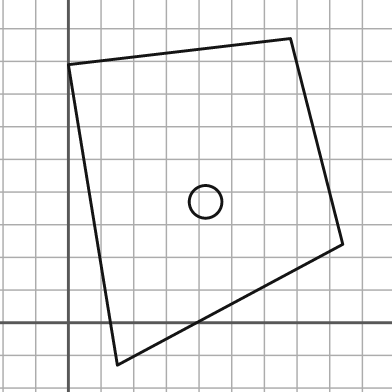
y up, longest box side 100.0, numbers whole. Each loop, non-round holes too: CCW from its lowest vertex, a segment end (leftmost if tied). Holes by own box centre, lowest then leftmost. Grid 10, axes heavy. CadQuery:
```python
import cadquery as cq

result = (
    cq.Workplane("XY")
    .moveTo(15.0, -13.0)
    .lineTo(84.0, 24.0)
    .lineTo(68.0, 87.0)
    .lineTo(0.0, 79.0)
    .close()
    .moveTo(42.0, 37.0)
    .circle(5.0)
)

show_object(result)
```